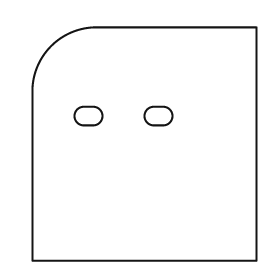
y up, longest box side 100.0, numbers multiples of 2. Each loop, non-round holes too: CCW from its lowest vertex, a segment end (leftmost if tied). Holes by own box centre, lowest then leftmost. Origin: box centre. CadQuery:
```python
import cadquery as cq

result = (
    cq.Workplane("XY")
    .moveTo(-48.0, -50.0)
    .lineTo(48.0, -50.0)
    .lineTo(48.0, 50.0)
    .lineTo(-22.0, 50.0)
    .threePointArc((-40.0, 42.0), (-48.0, 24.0))
    .close()
    .moveTo(-26.0, 8.0)
    .lineTo(-22.0, 8.0)
    .threePointArc((-18.0, 12.0), (-22.0, 16.0))
    .lineTo(-26.0, 16.0)
    .threePointArc((-30.0, 12.0), (-26.0, 8.0))
    .close()
    .moveTo(4.0, 8.0)
    .lineTo(8.0, 8.0)
    .threePointArc((12.0, 12.0), (8.0, 16.0))
    .lineTo(4.0, 16.0)
    .threePointArc((0.0, 12.0), (4.0, 8.0))
    .close()
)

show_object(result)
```